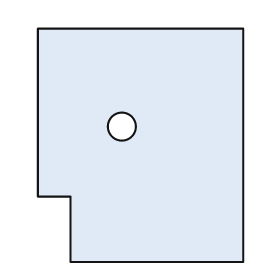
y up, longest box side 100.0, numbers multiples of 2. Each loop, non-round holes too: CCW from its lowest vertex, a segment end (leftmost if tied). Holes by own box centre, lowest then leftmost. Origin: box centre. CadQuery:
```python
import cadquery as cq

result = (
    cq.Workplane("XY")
    .moveTo(-30.0, -50.0)
    .lineTo(44.0, -50.0)
    .lineTo(44.0, 50.0)
    .lineTo(-44.0, 50.0)
    .lineTo(-44.0, -22.0)
    .lineTo(-30.0, -22.0)
    .close()
    .moveTo(-8.0, 8.0)
    .circle(6.0)
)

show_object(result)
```